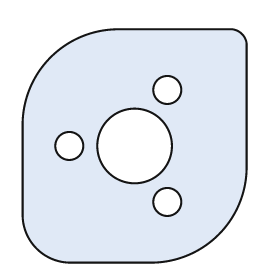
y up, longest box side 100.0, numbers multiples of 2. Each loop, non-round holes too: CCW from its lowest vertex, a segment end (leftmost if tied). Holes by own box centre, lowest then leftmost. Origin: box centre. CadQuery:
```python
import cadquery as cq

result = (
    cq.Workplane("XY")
    .moveTo(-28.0, -50.0)
    .lineTo(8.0, -50.0)
    .threePointArc((36.0, -38.0), (48.0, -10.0))
    .lineTo(48.0, 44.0)
    .threePointArc((46.0, 48.0), (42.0, 50.0))
    .lineTo(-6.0, 50.0)
    .threePointArc((-36.0, 38.0), (-48.0, 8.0))
    .lineTo(-48.0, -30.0)
    .threePointArc((-42.0, -44.0), (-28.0, -50.0))
    .close()
    .moveTo(14.0, -24.0)
    .circle(6.0)
    .moveTo(-28.0, 0.0)
    .circle(6.0)
    .moveTo(0.0, 0.0)
    .circle(16.0)
    .moveTo(14.0, 24.0)
    .circle(6.0)
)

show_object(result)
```